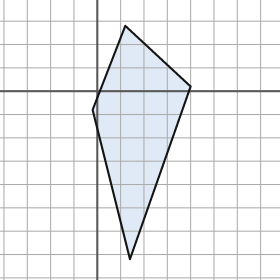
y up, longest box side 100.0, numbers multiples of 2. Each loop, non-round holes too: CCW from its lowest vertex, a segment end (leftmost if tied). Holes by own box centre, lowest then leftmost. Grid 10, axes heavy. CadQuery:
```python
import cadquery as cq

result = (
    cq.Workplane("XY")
    .moveTo(14.0, -72.0)
    .lineTo(40.0, 2.0)
    .lineTo(12.0, 28.0)
    .lineTo(-2.0, -8.0)
    .close()
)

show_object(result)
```